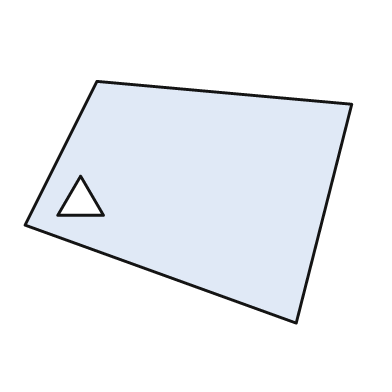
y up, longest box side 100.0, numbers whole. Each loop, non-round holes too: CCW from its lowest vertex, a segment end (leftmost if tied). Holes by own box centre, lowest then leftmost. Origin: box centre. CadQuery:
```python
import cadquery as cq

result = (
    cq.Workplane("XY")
    .moveTo(33.0, -37.0)
    .lineTo(50.0, 30.0)
    .lineTo(-28.0, 37.0)
    .lineTo(-50.0, -7.0)
    .close()
    .moveTo(-40.0, -4.0)
    .lineTo(-26.0, -4.0)
    .lineTo(-33.0, 8.0)
    .close()
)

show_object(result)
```